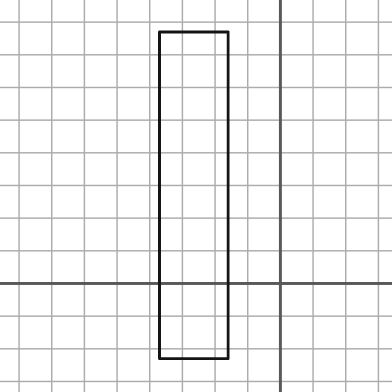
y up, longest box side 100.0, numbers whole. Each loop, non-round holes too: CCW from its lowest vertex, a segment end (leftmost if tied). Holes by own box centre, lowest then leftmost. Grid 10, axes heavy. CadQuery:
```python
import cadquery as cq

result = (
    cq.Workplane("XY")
    .moveTo(-37.0, -23.0)
    .lineTo(-16.0, -23.0)
    .lineTo(-16.0, 77.0)
    .lineTo(-37.0, 77.0)
    .close()
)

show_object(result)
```